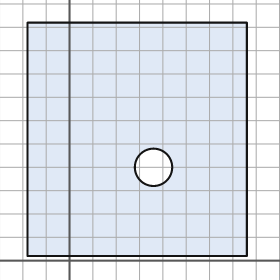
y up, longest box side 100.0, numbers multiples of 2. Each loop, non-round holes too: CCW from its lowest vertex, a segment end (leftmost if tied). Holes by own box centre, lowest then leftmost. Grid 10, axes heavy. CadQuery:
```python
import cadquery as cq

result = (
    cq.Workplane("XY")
    .moveTo(-18.0, 2.0)
    .lineTo(76.0, 2.0)
    .lineTo(76.0, 102.0)
    .lineTo(-18.0, 102.0)
    .close()
    .moveTo(36.0, 40.0)
    .circle(8.0)
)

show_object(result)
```